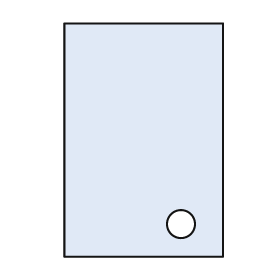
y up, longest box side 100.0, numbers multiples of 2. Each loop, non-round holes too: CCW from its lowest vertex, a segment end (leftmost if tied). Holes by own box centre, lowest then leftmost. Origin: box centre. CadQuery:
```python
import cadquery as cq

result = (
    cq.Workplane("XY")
    .moveTo(-34.0, -50.0)
    .lineTo(34.0, -50.0)
    .lineTo(34.0, 50.0)
    .lineTo(-34.0, 50.0)
    .close()
    .moveTo(16.0, -36.0)
    .circle(6.0)
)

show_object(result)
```